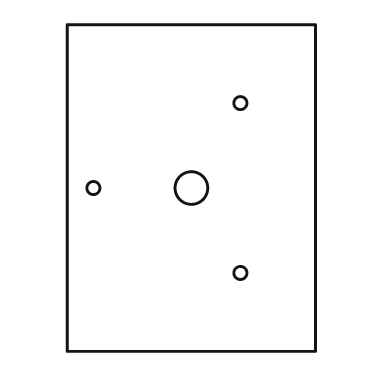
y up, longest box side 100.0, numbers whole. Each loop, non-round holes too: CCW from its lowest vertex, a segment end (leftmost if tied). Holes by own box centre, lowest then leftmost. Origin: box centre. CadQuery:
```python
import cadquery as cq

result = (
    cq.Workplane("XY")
    .moveTo(-38.0, -50.0)
    .lineTo(38.0, -50.0)
    .lineTo(38.0, 50.0)
    .lineTo(-38.0, 50.0)
    .close()
    .moveTo(15.0, -26.0)
    .circle(2.0)
    .moveTo(-30.0, 0.0)
    .circle(2.0)
    .moveTo(0.0, 0.0)
    .circle(5.0)
    .moveTo(15.0, 26.0)
    .circle(2.0)
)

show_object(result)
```